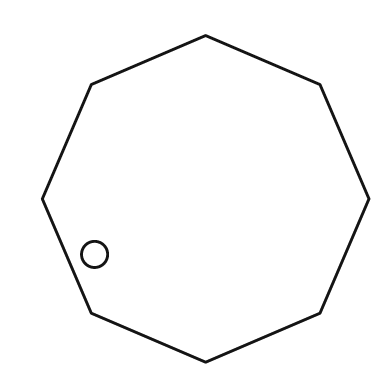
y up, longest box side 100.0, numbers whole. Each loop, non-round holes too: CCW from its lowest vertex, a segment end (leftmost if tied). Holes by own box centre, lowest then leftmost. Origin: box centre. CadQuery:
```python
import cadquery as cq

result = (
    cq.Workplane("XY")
    .moveTo(0.0, -50.0)
    .lineTo(35.0, -35.0)
    .lineTo(50.0, 0.0)
    .lineTo(35.0, 35.0)
    .lineTo(0.0, 50.0)
    .lineTo(-35.0, 35.0)
    .lineTo(-50.0, 0.0)
    .lineTo(-35.0, -35.0)
    .close()
    .moveTo(-34.0, -17.0)
    .circle(4.0)
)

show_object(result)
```